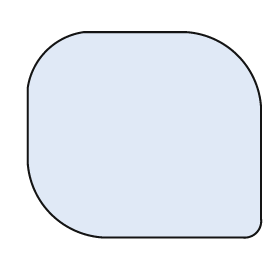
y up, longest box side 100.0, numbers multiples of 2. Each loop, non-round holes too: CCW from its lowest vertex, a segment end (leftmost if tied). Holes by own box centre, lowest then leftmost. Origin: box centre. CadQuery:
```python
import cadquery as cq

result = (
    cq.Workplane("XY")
    .moveTo(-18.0, -44.0)
    .lineTo(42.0, -44.0)
    .threePointArc((48.0, -42.0), (50.0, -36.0))
    .lineTo(50.0, 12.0)
    .threePointArc((40.0, 34.0), (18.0, 44.0))
    .lineTo(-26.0, 44.0)
    .threePointArc((-42.0, 36.0), (-50.0, 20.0))
    .lineTo(-50.0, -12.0)
    .threePointArc((-40.0, -34.0), (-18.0, -44.0))
    .close()
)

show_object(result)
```